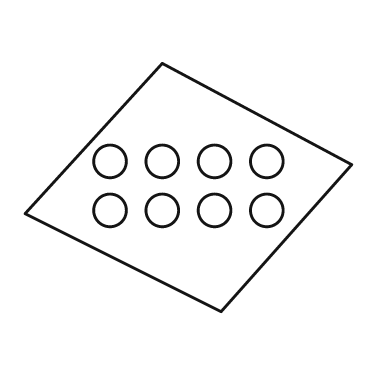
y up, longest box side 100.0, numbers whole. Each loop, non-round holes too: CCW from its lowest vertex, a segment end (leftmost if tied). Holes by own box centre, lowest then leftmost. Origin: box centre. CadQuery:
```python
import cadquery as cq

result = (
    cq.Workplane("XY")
    .moveTo(10.0, -38.0)
    .lineTo(50.0, 7.0)
    .lineTo(-8.0, 38.0)
    .lineTo(-50.0, -8.0)
    .close()
    .moveTo(-24.0, -7.0)
    .circle(5.0)
    .moveTo(-8.0, -7.0)
    .circle(5.0)
    .moveTo(8.0, -7.0)
    .circle(5.0)
    .moveTo(24.0, -7.0)
    .circle(5.0)
    .moveTo(-24.0, 8.0)
    .circle(5.0)
    .moveTo(-8.0, 8.0)
    .circle(5.0)
    .moveTo(8.0, 8.0)
    .circle(5.0)
    .moveTo(24.0, 8.0)
    .circle(5.0)
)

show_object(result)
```